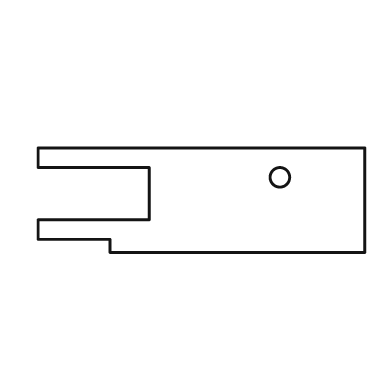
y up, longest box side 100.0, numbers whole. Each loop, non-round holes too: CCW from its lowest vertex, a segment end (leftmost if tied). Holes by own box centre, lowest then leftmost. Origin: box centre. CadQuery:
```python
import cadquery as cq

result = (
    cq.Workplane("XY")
    .moveTo(-28.0, -16.0)
    .lineTo(50.0, -16.0)
    .lineTo(50.0, 16.0)
    .lineTo(-50.0, 16.0)
    .lineTo(-50.0, 10.0)
    .lineTo(-16.0, 10.0)
    .lineTo(-16.0, -6.0)
    .lineTo(-50.0, -6.0)
    .lineTo(-50.0, -12.0)
    .lineTo(-28.0, -12.0)
    .close()
    .moveTo(24.0, 7.0)
    .circle(3.0)
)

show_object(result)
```